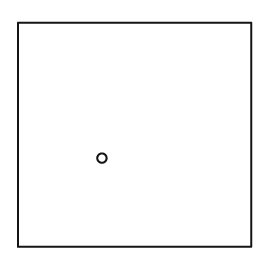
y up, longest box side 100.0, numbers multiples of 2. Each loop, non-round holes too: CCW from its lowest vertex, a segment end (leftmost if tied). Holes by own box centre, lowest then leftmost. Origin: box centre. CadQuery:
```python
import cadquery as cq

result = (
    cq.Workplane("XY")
    .moveTo(-50.0, -48.0)
    .lineTo(50.0, -48.0)
    .lineTo(50.0, 48.0)
    .lineTo(-50.0, 48.0)
    .close()
    .moveTo(-14.0, -10.0)
    .circle(2.0)
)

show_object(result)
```